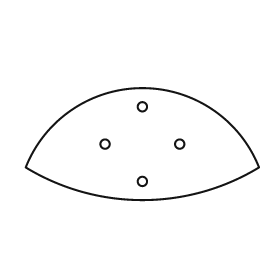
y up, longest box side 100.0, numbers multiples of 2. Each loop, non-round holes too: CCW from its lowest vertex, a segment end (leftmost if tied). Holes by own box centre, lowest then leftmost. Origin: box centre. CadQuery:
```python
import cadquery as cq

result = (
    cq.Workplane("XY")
    .moveTo(-50.0, -10.0)
    .threePointArc((0.0, -24.0), (50.0, -10.0))
    .threePointArc((0.0, 24.0), (-50.0, -10.0))
    .close()
    .moveTo(0.0, -16.0)
    .circle(2.0)
    .moveTo(-16.0, 0.0)
    .circle(2.0)
    .moveTo(16.0, 0.0)
    .circle(2.0)
    .moveTo(0.0, 16.0)
    .circle(2.0)
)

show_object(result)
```